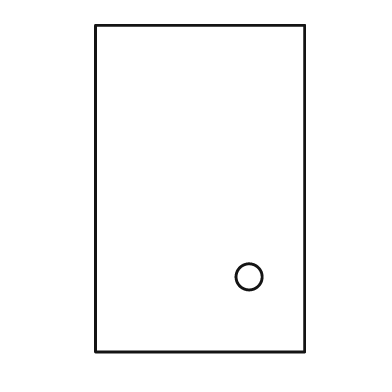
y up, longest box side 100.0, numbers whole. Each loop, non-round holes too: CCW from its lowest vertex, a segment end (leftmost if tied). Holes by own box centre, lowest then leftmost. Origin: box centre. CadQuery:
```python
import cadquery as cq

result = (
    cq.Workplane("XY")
    .moveTo(-32.0, -50.0)
    .lineTo(32.0, -50.0)
    .lineTo(32.0, 50.0)
    .lineTo(-32.0, 50.0)
    .close()
    .moveTo(15.0, -27.0)
    .circle(4.0)
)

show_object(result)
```